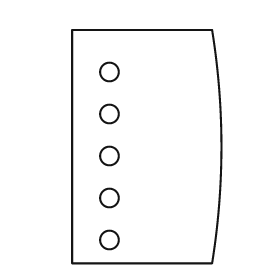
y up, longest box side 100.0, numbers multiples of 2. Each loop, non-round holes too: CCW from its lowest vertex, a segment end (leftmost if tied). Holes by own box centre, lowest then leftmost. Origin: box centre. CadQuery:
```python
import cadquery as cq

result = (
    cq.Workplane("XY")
    .moveTo(-32.0, -50.0)
    .lineTo(28.0, -50.0)
    .threePointArc((32.0, 0.0), (28.0, 50.0))
    .lineTo(-32.0, 50.0)
    .close()
    .moveTo(-16.0, -40.0)
    .circle(4.0)
    .moveTo(-16.0, -22.0)
    .circle(4.0)
    .moveTo(-16.0, -4.0)
    .circle(4.0)
    .moveTo(-16.0, 14.0)
    .circle(4.0)
    .moveTo(-16.0, 32.0)
    .circle(4.0)
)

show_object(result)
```